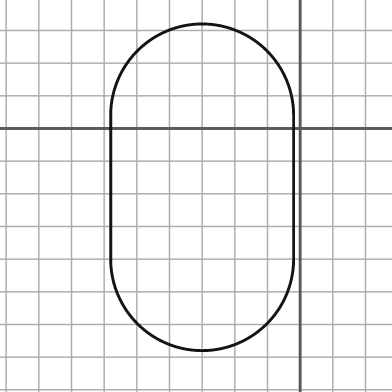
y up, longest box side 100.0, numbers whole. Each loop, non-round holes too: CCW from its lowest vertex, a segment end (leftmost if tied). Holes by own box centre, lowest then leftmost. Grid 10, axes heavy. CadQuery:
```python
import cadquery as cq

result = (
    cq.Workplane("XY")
    .moveTo(-58.0, -40.0)
    .threePointArc((-30.0, -68.0), (-2.0, -40.0))
    .lineTo(-2.0, 4.0)
    .threePointArc((-30.0, 32.0), (-58.0, 4.0))
    .close()
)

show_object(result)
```